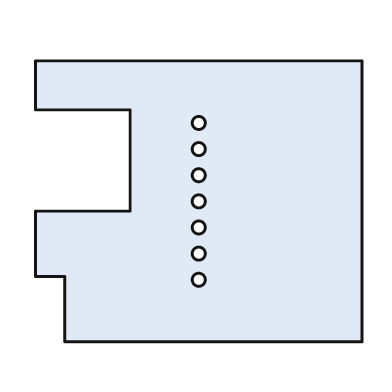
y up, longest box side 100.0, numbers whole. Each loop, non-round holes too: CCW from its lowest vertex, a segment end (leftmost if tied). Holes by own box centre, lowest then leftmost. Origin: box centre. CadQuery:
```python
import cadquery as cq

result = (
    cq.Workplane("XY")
    .moveTo(-41.0, -43.0)
    .lineTo(50.0, -43.0)
    .lineTo(50.0, 43.0)
    .lineTo(-50.0, 43.0)
    .lineTo(-50.0, 28.0)
    .lineTo(-21.0, 28.0)
    .lineTo(-21.0, -3.0)
    .lineTo(-50.0, -3.0)
    .lineTo(-50.0, -23.0)
    .lineTo(-41.0, -23.0)
    .close()
    .moveTo(0.0, -24.0)
    .circle(2.0)
    .moveTo(0.0, -16.0)
    .circle(2.0)
    .moveTo(0.0, -8.0)
    .circle(2.0)
    .moveTo(0.0, 0.0)
    .circle(2.0)
    .moveTo(0.0, 8.0)
    .circle(2.0)
    .moveTo(0.0, 16.0)
    .circle(2.0)
    .moveTo(0.0, 24.0)
    .circle(2.0)
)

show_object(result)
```